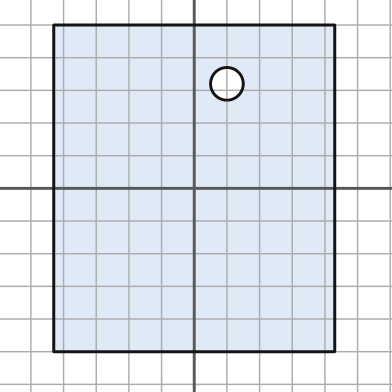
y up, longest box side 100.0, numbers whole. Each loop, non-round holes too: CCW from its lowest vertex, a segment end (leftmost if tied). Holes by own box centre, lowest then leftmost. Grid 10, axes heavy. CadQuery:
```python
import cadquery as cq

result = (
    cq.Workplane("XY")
    .moveTo(-43.0, -50.0)
    .lineTo(43.0, -50.0)
    .lineTo(43.0, 50.0)
    .lineTo(-43.0, 50.0)
    .close()
    .moveTo(10.0, 32.0)
    .circle(5.0)
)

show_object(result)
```